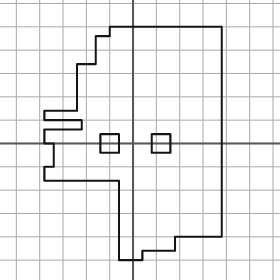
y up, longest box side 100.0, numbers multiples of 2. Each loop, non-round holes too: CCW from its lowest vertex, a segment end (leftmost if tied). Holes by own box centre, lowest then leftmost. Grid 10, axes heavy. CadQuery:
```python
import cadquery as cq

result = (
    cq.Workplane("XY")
    .moveTo(-6.0, -50.0)
    .lineTo(4.0, -50.0)
    .lineTo(4.0, -46.0)
    .lineTo(18.0, -46.0)
    .lineTo(18.0, -40.0)
    .lineTo(38.0, -40.0)
    .lineTo(38.0, 50.0)
    .lineTo(-10.0, 50.0)
    .lineTo(-10.0, 46.0)
    .lineTo(-16.0, 46.0)
    .lineTo(-16.0, 34.0)
    .lineTo(-24.0, 34.0)
    .lineTo(-24.0, 14.0)
    .lineTo(-38.0, 14.0)
    .lineTo(-38.0, 10.0)
    .lineTo(-22.0, 10.0)
    .lineTo(-22.0, 6.0)
    .lineTo(-38.0, 6.0)
    .lineTo(-38.0, 0.0)
    .lineTo(-34.0, 0.0)
    .lineTo(-34.0, -10.0)
    .lineTo(-38.0, -10.0)
    .lineTo(-38.0, -16.0)
    .lineTo(-6.0, -16.0)
    .close()
    .moveTo(-14.0, -4.0)
    .lineTo(-6.0, -4.0)
    .lineTo(-6.0, 4.0)
    .lineTo(-14.0, 4.0)
    .close()
    .moveTo(8.0, -4.0)
    .lineTo(16.0, -4.0)
    .lineTo(16.0, 4.0)
    .lineTo(8.0, 4.0)
    .close()
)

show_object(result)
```